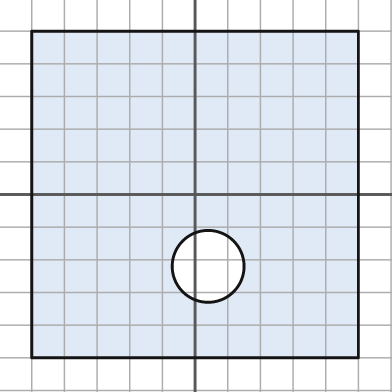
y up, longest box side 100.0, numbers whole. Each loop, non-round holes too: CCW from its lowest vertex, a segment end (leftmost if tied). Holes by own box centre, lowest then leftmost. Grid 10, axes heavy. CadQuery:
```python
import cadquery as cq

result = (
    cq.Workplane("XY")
    .moveTo(-50.0, -50.0)
    .lineTo(50.0, -50.0)
    .lineTo(50.0, 50.0)
    .lineTo(-50.0, 50.0)
    .close()
    .moveTo(4.0, -22.0)
    .circle(11.0)
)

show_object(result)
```